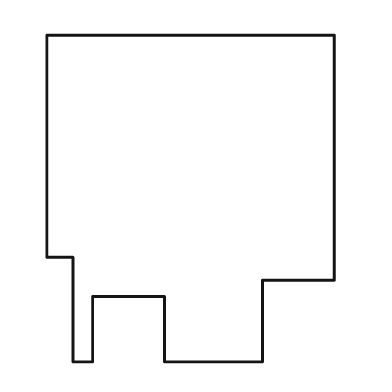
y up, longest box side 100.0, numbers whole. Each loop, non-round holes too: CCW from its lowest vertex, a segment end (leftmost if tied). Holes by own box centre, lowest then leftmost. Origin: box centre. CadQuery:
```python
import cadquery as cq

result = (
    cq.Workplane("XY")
    .moveTo(-36.0, -50.0)
    .lineTo(-30.0, -50.0)
    .lineTo(-30.0, -30.0)
    .lineTo(-8.0, -30.0)
    .lineTo(-8.0, -50.0)
    .lineTo(22.0, -50.0)
    .lineTo(22.0, -25.0)
    .lineTo(44.0, -25.0)
    .lineTo(44.0, 50.0)
    .lineTo(-44.0, 50.0)
    .lineTo(-44.0, -18.0)
    .lineTo(-36.0, -18.0)
    .close()
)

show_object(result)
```